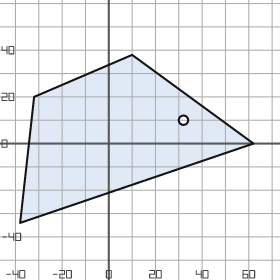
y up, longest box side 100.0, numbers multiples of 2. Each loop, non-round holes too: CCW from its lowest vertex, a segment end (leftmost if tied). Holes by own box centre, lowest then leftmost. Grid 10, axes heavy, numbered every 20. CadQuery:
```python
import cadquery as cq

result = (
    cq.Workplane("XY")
    .moveTo(-38.0, -34.0)
    .lineTo(62.0, 0.0)
    .lineTo(10.0, 38.0)
    .lineTo(-32.0, 20.0)
    .close()
    .moveTo(32.0, 10.0)
    .circle(2.0)
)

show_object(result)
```